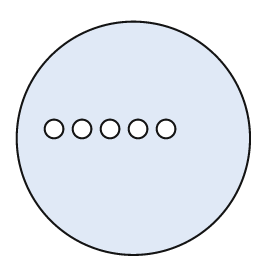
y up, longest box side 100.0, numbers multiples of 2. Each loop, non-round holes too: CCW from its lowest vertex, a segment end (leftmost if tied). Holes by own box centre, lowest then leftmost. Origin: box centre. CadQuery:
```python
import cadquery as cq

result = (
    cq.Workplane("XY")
    .moveTo(0.0, 0.0)
    .circle(50.0)
    .moveTo(-34.0, 4.0)
    .circle(4.0)
    .moveTo(-22.0, 4.0)
    .circle(4.0)
    .moveTo(-10.0, 4.0)
    .circle(4.0)
    .moveTo(2.0, 4.0)
    .circle(4.0)
    .moveTo(14.0, 4.0)
    .circle(4.0)
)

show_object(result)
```